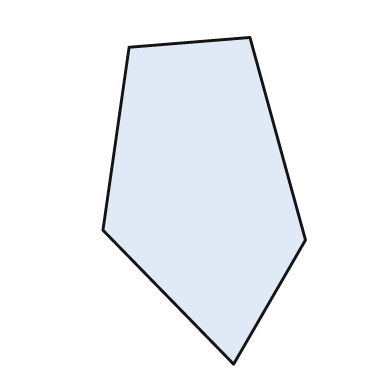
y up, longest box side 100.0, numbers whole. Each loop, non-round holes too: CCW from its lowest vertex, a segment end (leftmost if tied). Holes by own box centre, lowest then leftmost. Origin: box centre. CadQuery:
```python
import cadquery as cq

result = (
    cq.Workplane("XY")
    .moveTo(9.0, -50.0)
    .lineTo(31.0, -12.0)
    .lineTo(14.0, 50.0)
    .lineTo(-23.0, 47.0)
    .lineTo(-31.0, -9.0)
    .close()
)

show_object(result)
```